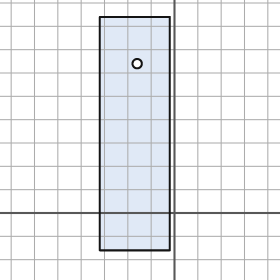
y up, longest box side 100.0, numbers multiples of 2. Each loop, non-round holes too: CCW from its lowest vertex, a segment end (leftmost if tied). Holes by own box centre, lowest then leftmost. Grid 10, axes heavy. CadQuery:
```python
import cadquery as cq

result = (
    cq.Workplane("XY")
    .moveTo(-32.0, -16.0)
    .lineTo(-2.0, -16.0)
    .lineTo(-2.0, 84.0)
    .lineTo(-32.0, 84.0)
    .close()
    .moveTo(-16.0, 64.0)
    .circle(2.0)
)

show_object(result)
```